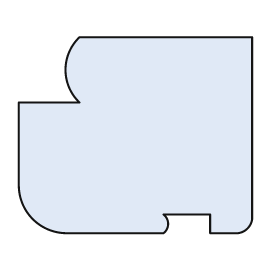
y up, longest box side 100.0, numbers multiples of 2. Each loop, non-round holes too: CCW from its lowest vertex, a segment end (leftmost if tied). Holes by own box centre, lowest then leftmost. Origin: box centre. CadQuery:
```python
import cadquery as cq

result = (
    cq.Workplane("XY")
    .moveTo(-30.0, -42.0)
    .lineTo(12.0, -42.0)
    .threePointArc((14.0, -38.0), (12.0, -34.0))
    .lineTo(32.0, -34.0)
    .lineTo(32.0, -42.0)
    .lineTo(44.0, -42.0)
    .threePointArc((48.0, -40.0), (50.0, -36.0))
    .lineTo(50.0, 42.0)
    .lineTo(-24.0, 42.0)
    .threePointArc((-30.0, 28.0), (-24.0, 14.0))
    .lineTo(-50.0, 14.0)
    .lineTo(-50.0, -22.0)
    .threePointArc((-44.0, -36.0), (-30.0, -42.0))
    .close()
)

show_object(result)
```